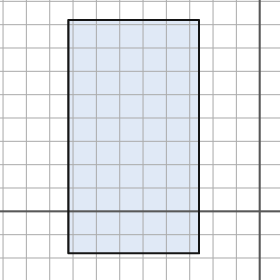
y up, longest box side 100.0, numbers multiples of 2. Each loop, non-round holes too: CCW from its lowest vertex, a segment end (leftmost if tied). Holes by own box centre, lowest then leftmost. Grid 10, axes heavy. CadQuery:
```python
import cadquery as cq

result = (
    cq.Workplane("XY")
    .moveTo(-82.0, -18.0)
    .lineTo(-26.0, -18.0)
    .lineTo(-26.0, 82.0)
    .lineTo(-82.0, 82.0)
    .close()
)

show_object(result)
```